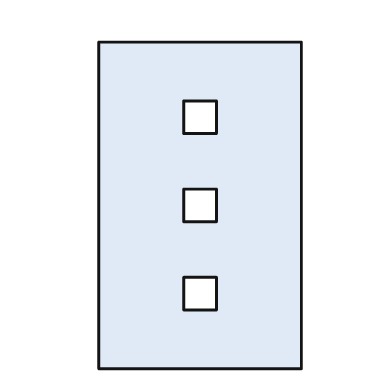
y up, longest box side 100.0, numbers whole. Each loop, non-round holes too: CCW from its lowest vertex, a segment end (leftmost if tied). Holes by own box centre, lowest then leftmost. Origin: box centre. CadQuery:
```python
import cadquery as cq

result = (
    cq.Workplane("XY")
    .moveTo(-31.0, -50.0)
    .lineTo(31.0, -50.0)
    .lineTo(31.0, 50.0)
    .lineTo(-31.0, 50.0)
    .close()
    .moveTo(-5.0, -32.0)
    .lineTo(5.0, -32.0)
    .lineTo(5.0, -22.0)
    .lineTo(-5.0, -22.0)
    .close()
    .moveTo(-5.0, -5.0)
    .lineTo(5.0, -5.0)
    .lineTo(5.0, 5.0)
    .lineTo(-5.0, 5.0)
    .close()
    .moveTo(-5.0, 22.0)
    .lineTo(5.0, 22.0)
    .lineTo(5.0, 32.0)
    .lineTo(-5.0, 32.0)
    .close()
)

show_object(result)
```